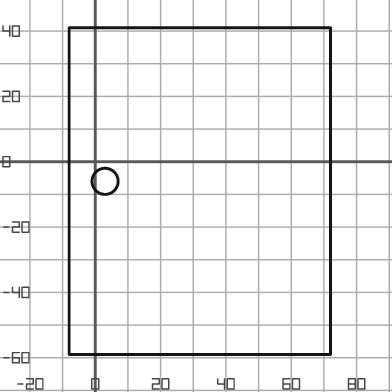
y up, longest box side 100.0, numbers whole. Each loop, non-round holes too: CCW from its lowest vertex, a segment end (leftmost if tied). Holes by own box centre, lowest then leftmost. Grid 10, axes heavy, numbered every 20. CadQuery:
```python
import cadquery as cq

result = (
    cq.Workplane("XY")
    .moveTo(-8.0, -59.0)
    .lineTo(72.0, -59.0)
    .lineTo(72.0, 41.0)
    .lineTo(-8.0, 41.0)
    .close()
    .moveTo(3.0, -6.0)
    .circle(4.0)
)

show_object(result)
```